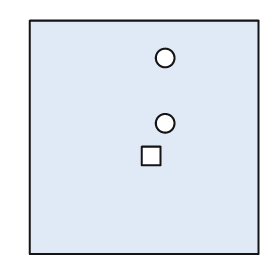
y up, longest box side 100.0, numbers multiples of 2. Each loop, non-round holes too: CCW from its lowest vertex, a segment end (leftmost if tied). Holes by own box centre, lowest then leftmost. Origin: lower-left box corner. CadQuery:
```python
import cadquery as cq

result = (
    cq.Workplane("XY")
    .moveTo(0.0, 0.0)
    .lineTo(98.0, 0.0)
    .lineTo(98.0, 100.0)
    .lineTo(0.0, 100.0)
    .close()
    .moveTo(48.0, 38.0)
    .lineTo(56.0, 38.0)
    .lineTo(56.0, 46.0)
    .lineTo(48.0, 46.0)
    .close()
    .moveTo(58.0, 56.0)
    .circle(4.0)
    .moveTo(58.0, 84.0)
    .circle(4.0)
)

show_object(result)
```